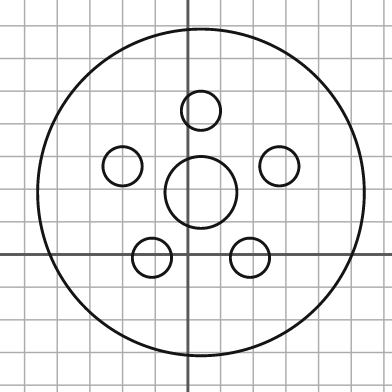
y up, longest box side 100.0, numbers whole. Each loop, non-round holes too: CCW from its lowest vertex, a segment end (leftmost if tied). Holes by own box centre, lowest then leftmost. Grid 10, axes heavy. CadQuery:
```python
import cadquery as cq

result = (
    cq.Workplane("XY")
    .moveTo(4.0, 19.0)
    .circle(50.0)
    .moveTo(-11.0, -1.0)
    .circle(6.0)
    .moveTo(19.0, -1.0)
    .circle(6.0)
    .moveTo(4.0, 19.0)
    .circle(11.0)
    .moveTo(-20.0, 27.0)
    .circle(6.0)
    .moveTo(28.0, 27.0)
    .circle(6.0)
    .moveTo(4.0, 44.0)
    .circle(6.0)
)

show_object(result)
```